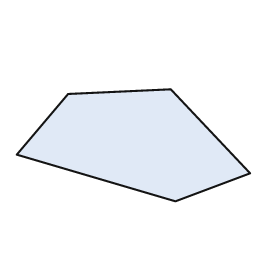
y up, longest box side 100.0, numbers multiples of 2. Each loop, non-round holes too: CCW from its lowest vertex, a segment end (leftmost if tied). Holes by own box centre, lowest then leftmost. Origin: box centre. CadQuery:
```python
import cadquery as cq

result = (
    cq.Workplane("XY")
    .moveTo(18.0, -24.0)
    .lineTo(50.0, -12.0)
    .lineTo(16.0, 24.0)
    .lineTo(-28.0, 22.0)
    .lineTo(-50.0, -4.0)
    .close()
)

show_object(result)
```